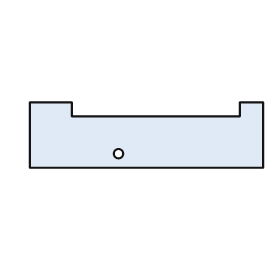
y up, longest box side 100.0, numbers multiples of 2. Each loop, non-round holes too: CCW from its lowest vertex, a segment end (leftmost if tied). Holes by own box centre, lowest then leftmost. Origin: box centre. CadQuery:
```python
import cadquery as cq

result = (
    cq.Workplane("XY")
    .moveTo(-50.0, -14.0)
    .lineTo(50.0, -14.0)
    .lineTo(50.0, 14.0)
    .lineTo(40.0, 14.0)
    .lineTo(40.0, 8.0)
    .lineTo(-32.0, 8.0)
    .lineTo(-32.0, 14.0)
    .lineTo(-50.0, 14.0)
    .close()
    .moveTo(-12.0, -8.0)
    .circle(2.0)
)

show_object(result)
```